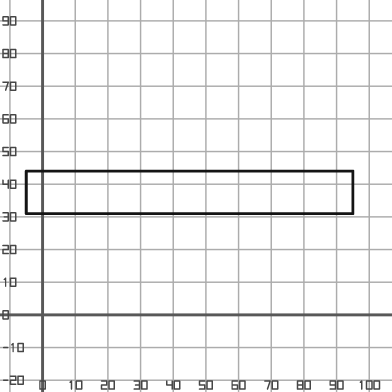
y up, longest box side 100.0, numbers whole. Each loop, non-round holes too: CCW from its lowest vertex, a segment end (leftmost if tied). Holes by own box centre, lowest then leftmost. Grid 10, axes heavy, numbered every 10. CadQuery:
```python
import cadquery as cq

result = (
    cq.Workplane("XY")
    .moveTo(-5.0, 31.0)
    .lineTo(95.0, 31.0)
    .lineTo(95.0, 44.0)
    .lineTo(-5.0, 44.0)
    .close()
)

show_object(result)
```